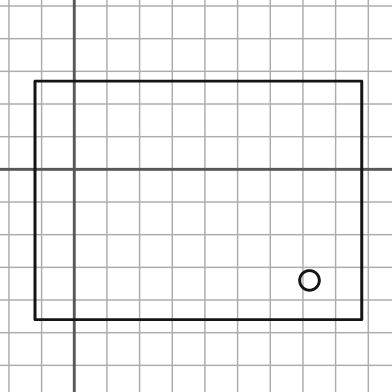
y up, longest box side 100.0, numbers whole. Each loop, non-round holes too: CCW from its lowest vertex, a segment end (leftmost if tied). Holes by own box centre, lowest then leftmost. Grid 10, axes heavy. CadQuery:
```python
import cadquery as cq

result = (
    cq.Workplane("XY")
    .moveTo(-12.0, -46.0)
    .lineTo(88.0, -46.0)
    .lineTo(88.0, 27.0)
    .lineTo(-12.0, 27.0)
    .close()
    .moveTo(72.0, -34.0)
    .circle(3.0)
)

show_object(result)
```